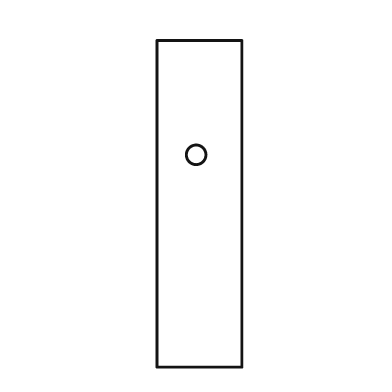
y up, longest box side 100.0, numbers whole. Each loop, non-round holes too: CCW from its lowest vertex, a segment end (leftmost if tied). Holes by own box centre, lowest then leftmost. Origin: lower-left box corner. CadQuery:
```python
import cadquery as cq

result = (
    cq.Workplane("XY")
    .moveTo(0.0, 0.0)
    .lineTo(26.0, 0.0)
    .lineTo(26.0, 100.0)
    .lineTo(0.0, 100.0)
    .close()
    .moveTo(12.0, 65.0)
    .circle(3.0)
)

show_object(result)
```